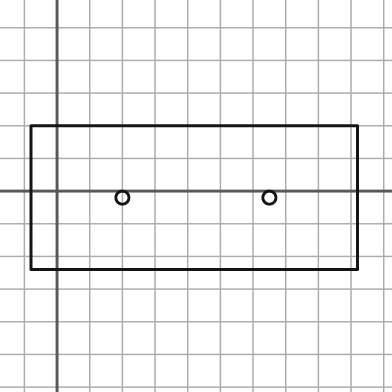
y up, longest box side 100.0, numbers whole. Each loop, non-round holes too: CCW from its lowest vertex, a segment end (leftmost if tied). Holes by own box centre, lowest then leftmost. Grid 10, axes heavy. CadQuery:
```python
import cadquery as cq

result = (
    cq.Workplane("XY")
    .moveTo(-8.0, -24.0)
    .lineTo(92.0, -24.0)
    .lineTo(92.0, 20.0)
    .lineTo(-8.0, 20.0)
    .close()
    .moveTo(20.0, -2.0)
    .circle(2.0)
    .moveTo(65.0, -2.0)
    .circle(2.0)
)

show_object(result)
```